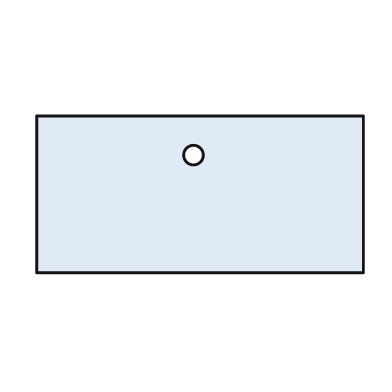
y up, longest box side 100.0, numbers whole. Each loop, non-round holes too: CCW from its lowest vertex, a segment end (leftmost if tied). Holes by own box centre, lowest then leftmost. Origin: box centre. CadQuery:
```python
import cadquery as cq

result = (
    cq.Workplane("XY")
    .moveTo(-50.0, -24.0)
    .lineTo(50.0, -24.0)
    .lineTo(50.0, 24.0)
    .lineTo(-50.0, 24.0)
    .close()
    .moveTo(-2.0, 12.0)
    .circle(3.0)
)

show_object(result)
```